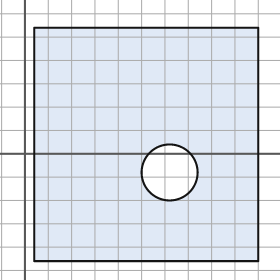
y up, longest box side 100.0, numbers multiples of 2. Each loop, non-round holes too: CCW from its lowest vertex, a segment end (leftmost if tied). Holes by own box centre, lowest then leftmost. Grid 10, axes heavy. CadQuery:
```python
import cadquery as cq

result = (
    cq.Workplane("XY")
    .moveTo(4.0, -46.0)
    .lineTo(100.0, -46.0)
    .lineTo(100.0, 54.0)
    .lineTo(4.0, 54.0)
    .close()
    .moveTo(62.0, -8.0)
    .circle(12.0)
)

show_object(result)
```